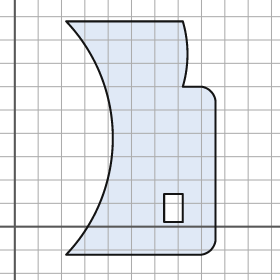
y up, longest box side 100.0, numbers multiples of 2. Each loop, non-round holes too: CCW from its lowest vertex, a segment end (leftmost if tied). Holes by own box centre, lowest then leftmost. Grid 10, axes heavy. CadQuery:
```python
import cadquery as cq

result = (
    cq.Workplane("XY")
    .moveTo(22.0, -12.0)
    .lineTo(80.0, -12.0)
    .threePointArc((84.0, -10.0), (86.0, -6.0))
    .lineTo(86.0, 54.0)
    .threePointArc((84.0, 58.0), (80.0, 60.0))
    .lineTo(72.0, 60.0)
    .threePointArc((74.0, 74.0), (72.0, 88.0))
    .lineTo(22.0, 88.0)
    .threePointArc((42.0, 38.0), (22.0, -12.0))
    .close()
    .moveTo(64.0, 2.0)
    .lineTo(72.0, 2.0)
    .lineTo(72.0, 14.0)
    .lineTo(64.0, 14.0)
    .close()
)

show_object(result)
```